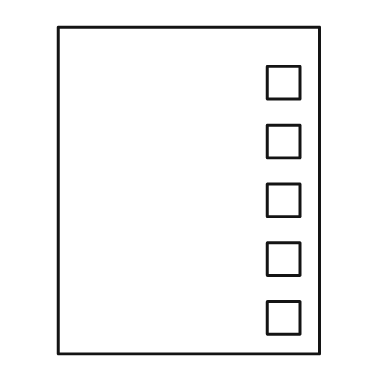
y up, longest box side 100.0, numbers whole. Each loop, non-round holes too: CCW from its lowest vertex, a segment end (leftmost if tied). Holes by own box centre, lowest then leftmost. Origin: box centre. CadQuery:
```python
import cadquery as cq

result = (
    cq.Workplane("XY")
    .moveTo(-40.0, -50.0)
    .lineTo(40.0, -50.0)
    .lineTo(40.0, 50.0)
    .lineTo(-40.0, 50.0)
    .close()
    .moveTo(24.0, -44.0)
    .lineTo(34.0, -44.0)
    .lineTo(34.0, -34.0)
    .lineTo(24.0, -34.0)
    .close()
    .moveTo(24.0, -26.0)
    .lineTo(34.0, -26.0)
    .lineTo(34.0, -16.0)
    .lineTo(24.0, -16.0)
    .close()
    .moveTo(24.0, -8.0)
    .lineTo(34.0, -8.0)
    .lineTo(34.0, 2.0)
    .lineTo(24.0, 2.0)
    .close()
    .moveTo(24.0, 10.0)
    .lineTo(34.0, 10.0)
    .lineTo(34.0, 20.0)
    .lineTo(24.0, 20.0)
    .close()
    .moveTo(24.0, 28.0)
    .lineTo(34.0, 28.0)
    .lineTo(34.0, 38.0)
    .lineTo(24.0, 38.0)
    .close()
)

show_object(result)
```